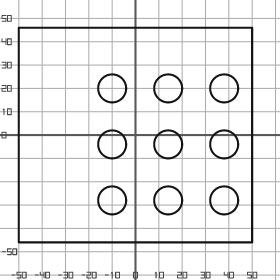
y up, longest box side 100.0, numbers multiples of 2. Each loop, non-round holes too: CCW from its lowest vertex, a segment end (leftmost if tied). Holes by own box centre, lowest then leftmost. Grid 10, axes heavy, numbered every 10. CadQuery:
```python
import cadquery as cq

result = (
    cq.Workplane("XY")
    .moveTo(-50.0, -46.0)
    .lineTo(50.0, -46.0)
    .lineTo(50.0, 46.0)
    .lineTo(-50.0, 46.0)
    .close()
    .moveTo(-10.0, -28.0)
    .circle(6.0)
    .moveTo(14.0, -28.0)
    .circle(6.0)
    .moveTo(38.0, -28.0)
    .circle(6.0)
    .moveTo(-10.0, -4.0)
    .circle(6.0)
    .moveTo(14.0, -4.0)
    .circle(6.0)
    .moveTo(38.0, -4.0)
    .circle(6.0)
    .moveTo(-10.0, 20.0)
    .circle(6.0)
    .moveTo(14.0, 20.0)
    .circle(6.0)
    .moveTo(38.0, 20.0)
    .circle(6.0)
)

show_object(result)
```